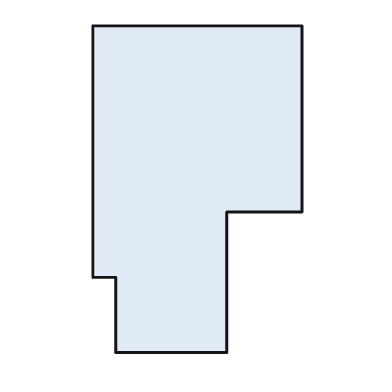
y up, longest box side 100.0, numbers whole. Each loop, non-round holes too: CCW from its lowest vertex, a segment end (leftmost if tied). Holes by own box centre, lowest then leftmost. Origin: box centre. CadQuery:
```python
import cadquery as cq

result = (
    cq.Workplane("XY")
    .moveTo(-25.0, -50.0)
    .lineTo(9.0, -50.0)
    .lineTo(9.0, -7.0)
    .lineTo(32.0, -7.0)
    .lineTo(32.0, 50.0)
    .lineTo(-32.0, 50.0)
    .lineTo(-32.0, -27.0)
    .lineTo(-25.0, -27.0)
    .close()
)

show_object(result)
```